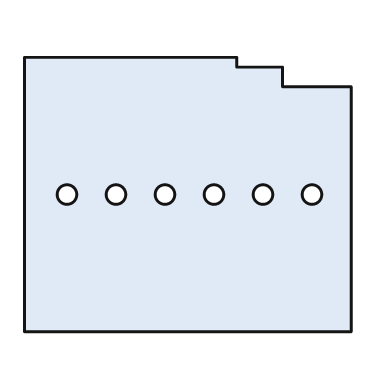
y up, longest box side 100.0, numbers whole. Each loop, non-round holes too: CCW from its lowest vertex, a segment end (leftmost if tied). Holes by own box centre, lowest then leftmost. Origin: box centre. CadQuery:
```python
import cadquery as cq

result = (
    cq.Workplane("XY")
    .moveTo(-50.0, -42.0)
    .lineTo(50.0, -42.0)
    .lineTo(50.0, 33.0)
    .lineTo(29.0, 33.0)
    .lineTo(29.0, 39.0)
    .lineTo(15.0, 39.0)
    .lineTo(15.0, 42.0)
    .lineTo(-50.0, 42.0)
    .close()
    .moveTo(-37.0, 0.0)
    .circle(3.0)
    .moveTo(-22.0, 0.0)
    .circle(3.0)
    .moveTo(-7.0, 0.0)
    .circle(3.0)
    .moveTo(8.0, 0.0)
    .circle(3.0)
    .moveTo(23.0, 0.0)
    .circle(3.0)
    .moveTo(38.0, 0.0)
    .circle(3.0)
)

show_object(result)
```